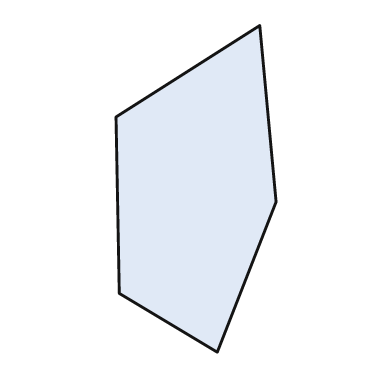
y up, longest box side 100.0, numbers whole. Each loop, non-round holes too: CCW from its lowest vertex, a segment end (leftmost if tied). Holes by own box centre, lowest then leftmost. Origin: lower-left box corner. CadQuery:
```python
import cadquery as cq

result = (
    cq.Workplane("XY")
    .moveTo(31.0, 0.0)
    .lineTo(49.0, 46.0)
    .lineTo(44.0, 100.0)
    .lineTo(0.0, 72.0)
    .lineTo(1.0, 18.0)
    .close()
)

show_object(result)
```